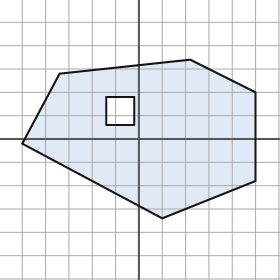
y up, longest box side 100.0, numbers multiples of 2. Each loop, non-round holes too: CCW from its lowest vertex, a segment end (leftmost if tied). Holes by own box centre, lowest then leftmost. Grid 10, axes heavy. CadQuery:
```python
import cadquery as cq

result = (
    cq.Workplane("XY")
    .moveTo(10.0, -34.0)
    .lineTo(50.0, -18.0)
    .lineTo(50.0, 20.0)
    .lineTo(22.0, 34.0)
    .lineTo(-34.0, 28.0)
    .lineTo(-50.0, -2.0)
    .close()
    .moveTo(-14.0, 6.0)
    .lineTo(-2.0, 6.0)
    .lineTo(-2.0, 18.0)
    .lineTo(-14.0, 18.0)
    .close()
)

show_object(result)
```